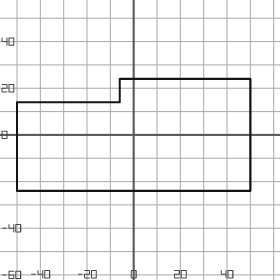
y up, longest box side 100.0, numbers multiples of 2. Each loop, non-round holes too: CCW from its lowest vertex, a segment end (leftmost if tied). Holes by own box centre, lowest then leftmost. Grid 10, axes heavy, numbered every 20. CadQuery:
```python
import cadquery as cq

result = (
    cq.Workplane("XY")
    .moveTo(-50.0, -24.0)
    .lineTo(50.0, -24.0)
    .lineTo(50.0, 24.0)
    .lineTo(-6.0, 24.0)
    .lineTo(-6.0, 14.0)
    .lineTo(-50.0, 14.0)
    .close()
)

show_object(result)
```